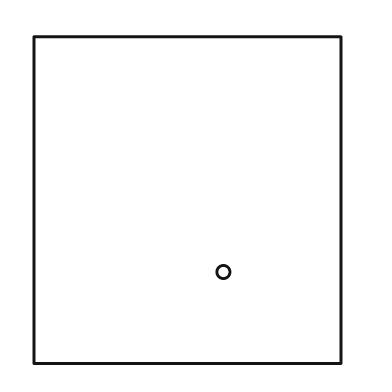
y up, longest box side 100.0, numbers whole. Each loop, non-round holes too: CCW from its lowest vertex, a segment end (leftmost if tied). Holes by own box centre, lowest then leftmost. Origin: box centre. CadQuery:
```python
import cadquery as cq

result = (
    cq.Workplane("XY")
    .moveTo(-47.0, -50.0)
    .lineTo(47.0, -50.0)
    .lineTo(47.0, 50.0)
    .lineTo(-47.0, 50.0)
    .close()
    .moveTo(11.0, -22.0)
    .circle(2.0)
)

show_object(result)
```